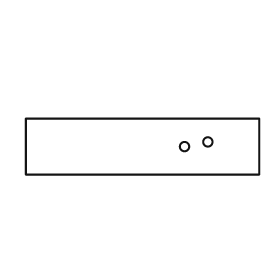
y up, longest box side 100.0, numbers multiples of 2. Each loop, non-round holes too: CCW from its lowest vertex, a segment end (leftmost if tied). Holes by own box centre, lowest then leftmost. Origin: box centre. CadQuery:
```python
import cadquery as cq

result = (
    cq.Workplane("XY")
    .moveTo(-50.0, -12.0)
    .lineTo(50.0, -12.0)
    .lineTo(50.0, 12.0)
    .lineTo(-50.0, 12.0)
    .close()
    .moveTo(18.0, 0.0)
    .circle(2.0)
    .moveTo(28.0, 2.0)
    .circle(2.0)
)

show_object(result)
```